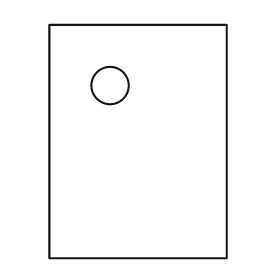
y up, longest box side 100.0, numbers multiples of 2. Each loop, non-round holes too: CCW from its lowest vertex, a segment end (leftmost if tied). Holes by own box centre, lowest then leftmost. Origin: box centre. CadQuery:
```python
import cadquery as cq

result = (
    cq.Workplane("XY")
    .moveTo(-38.0, -50.0)
    .lineTo(38.0, -50.0)
    .lineTo(38.0, 50.0)
    .lineTo(-38.0, 50.0)
    .close()
    .moveTo(-12.0, 24.0)
    .circle(8.0)
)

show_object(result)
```